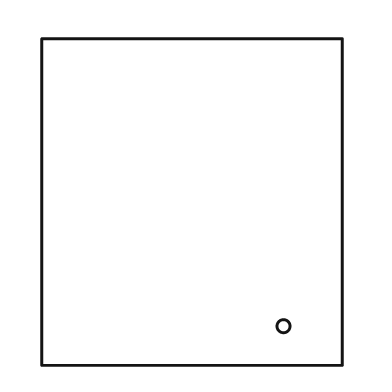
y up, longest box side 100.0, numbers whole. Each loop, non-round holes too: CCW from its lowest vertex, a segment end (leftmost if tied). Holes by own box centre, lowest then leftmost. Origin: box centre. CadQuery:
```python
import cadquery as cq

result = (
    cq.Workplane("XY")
    .moveTo(-46.0, -50.0)
    .lineTo(46.0, -50.0)
    .lineTo(46.0, 50.0)
    .lineTo(-46.0, 50.0)
    .close()
    .moveTo(28.0, -38.0)
    .circle(2.0)
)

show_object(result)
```